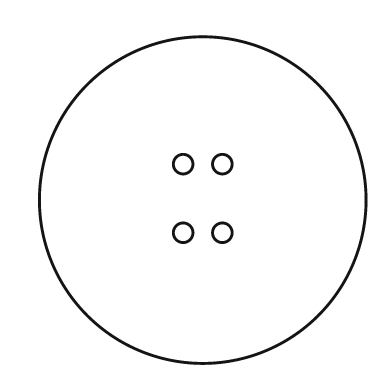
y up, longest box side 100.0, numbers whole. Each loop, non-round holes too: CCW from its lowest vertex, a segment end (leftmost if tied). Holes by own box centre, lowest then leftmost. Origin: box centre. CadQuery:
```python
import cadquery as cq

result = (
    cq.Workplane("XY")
    .moveTo(0.0, 0.0)
    .circle(50.0)
    .moveTo(-6.0, -10.0)
    .circle(3.0)
    .moveTo(6.0, -10.0)
    .circle(3.0)
    .moveTo(-6.0, 11.0)
    .circle(3.0)
    .moveTo(6.0, 11.0)
    .circle(3.0)
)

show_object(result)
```